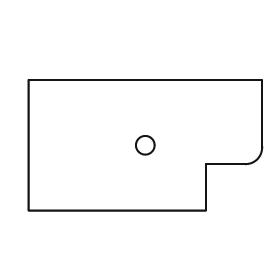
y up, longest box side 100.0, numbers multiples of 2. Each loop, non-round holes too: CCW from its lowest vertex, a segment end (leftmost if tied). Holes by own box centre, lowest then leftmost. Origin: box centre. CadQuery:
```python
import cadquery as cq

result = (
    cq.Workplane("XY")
    .moveTo(-50.0, -28.0)
    .lineTo(26.0, -28.0)
    .lineTo(26.0, -8.0)
    .lineTo(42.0, -8.0)
    .threePointArc((48.0, -6.0), (50.0, 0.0))
    .lineTo(50.0, 28.0)
    .lineTo(-50.0, 28.0)
    .close()
    .moveTo(0.0, 0.0)
    .circle(4.0)
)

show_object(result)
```